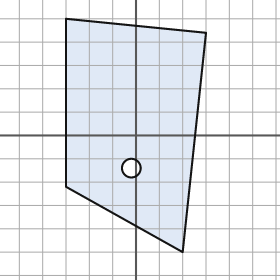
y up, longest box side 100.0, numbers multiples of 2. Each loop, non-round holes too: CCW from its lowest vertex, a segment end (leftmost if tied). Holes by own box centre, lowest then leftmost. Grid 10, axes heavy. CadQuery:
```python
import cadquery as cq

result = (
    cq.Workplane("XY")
    .moveTo(20.0, -50.0)
    .lineTo(30.0, 44.0)
    .lineTo(-30.0, 50.0)
    .lineTo(-30.0, -22.0)
    .close()
    .moveTo(-2.0, -14.0)
    .circle(4.0)
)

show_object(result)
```